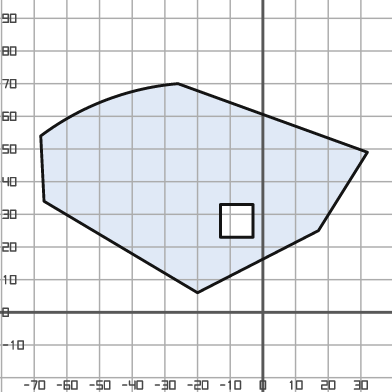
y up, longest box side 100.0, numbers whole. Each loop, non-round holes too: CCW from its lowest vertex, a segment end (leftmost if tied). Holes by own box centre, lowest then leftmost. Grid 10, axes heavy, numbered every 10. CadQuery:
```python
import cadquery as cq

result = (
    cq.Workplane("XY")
    .moveTo(-20.0, 6.0)
    .lineTo(17.0, 25.0)
    .lineTo(32.0, 49.0)
    .lineTo(-26.0, 70.0)
    .threePointArc((-48.0, 65.0), (-68.0, 54.0))
    .lineTo(-67.0, 34.0)
    .close()
    .moveTo(-13.0, 23.0)
    .lineTo(-3.0, 23.0)
    .lineTo(-3.0, 33.0)
    .lineTo(-13.0, 33.0)
    .close()
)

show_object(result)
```